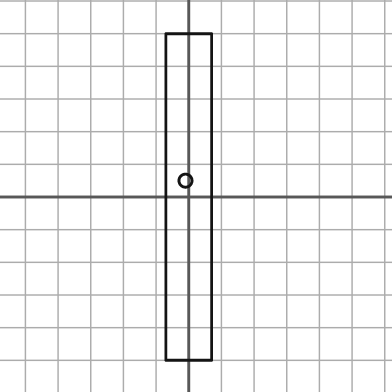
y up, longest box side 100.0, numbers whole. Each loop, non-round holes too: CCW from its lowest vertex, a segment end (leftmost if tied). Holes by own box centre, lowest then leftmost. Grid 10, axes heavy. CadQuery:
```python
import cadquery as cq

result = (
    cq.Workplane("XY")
    .moveTo(-7.0, -50.0)
    .lineTo(7.0, -50.0)
    .lineTo(7.0, 50.0)
    .lineTo(-7.0, 50.0)
    .close()
    .moveTo(-1.0, 5.0)
    .circle(2.0)
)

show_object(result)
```